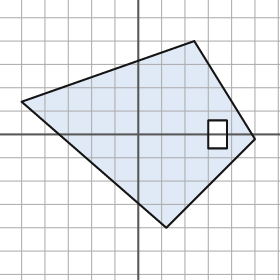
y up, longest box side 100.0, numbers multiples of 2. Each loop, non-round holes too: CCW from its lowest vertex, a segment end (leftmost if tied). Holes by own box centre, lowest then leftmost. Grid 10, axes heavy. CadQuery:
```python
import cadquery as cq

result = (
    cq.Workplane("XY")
    .moveTo(12.0, -40.0)
    .lineTo(50.0, -2.0)
    .lineTo(24.0, 40.0)
    .lineTo(-50.0, 14.0)
    .close()
    .moveTo(30.0, -6.0)
    .lineTo(38.0, -6.0)
    .lineTo(38.0, 6.0)
    .lineTo(30.0, 6.0)
    .close()
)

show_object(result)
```